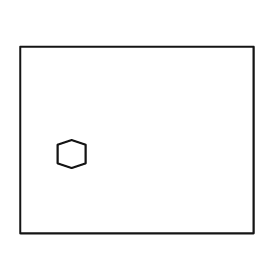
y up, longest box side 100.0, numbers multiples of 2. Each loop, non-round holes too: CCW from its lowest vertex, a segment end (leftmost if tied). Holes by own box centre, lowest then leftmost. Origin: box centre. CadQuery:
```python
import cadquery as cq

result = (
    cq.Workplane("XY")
    .moveTo(-50.0, -40.0)
    .lineTo(50.0, -40.0)
    .lineTo(50.0, 40.0)
    .lineTo(-50.0, 40.0)
    .close()
    .moveTo(-28.0, -12.0)
    .lineTo(-22.0, -10.0)
    .lineTo(-22.0, -2.0)
    .lineTo(-28.0, 0.0)
    .lineTo(-34.0, -2.0)
    .lineTo(-34.0, -10.0)
    .close()
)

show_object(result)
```